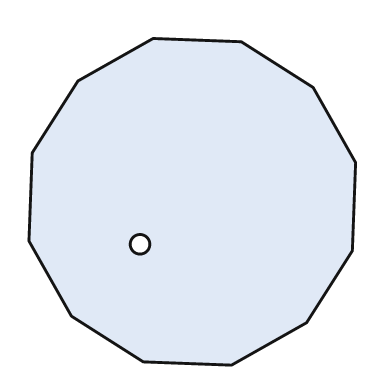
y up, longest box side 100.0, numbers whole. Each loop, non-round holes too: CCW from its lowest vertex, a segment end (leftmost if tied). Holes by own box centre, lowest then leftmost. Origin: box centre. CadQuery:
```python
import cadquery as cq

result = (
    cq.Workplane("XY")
    .moveTo(12.0, -50.0)
    .lineTo(35.0, -37.0)
    .lineTo(49.0, -15.0)
    .lineTo(50.0, 12.0)
    .lineTo(37.0, 35.0)
    .lineTo(15.0, 49.0)
    .lineTo(-12.0, 50.0)
    .lineTo(-35.0, 37.0)
    .lineTo(-49.0, 15.0)
    .lineTo(-50.0, -12.0)
    .lineTo(-37.0, -35.0)
    .lineTo(-15.0, -49.0)
    .close()
    .moveTo(-16.0, -13.0)
    .circle(3.0)
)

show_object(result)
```